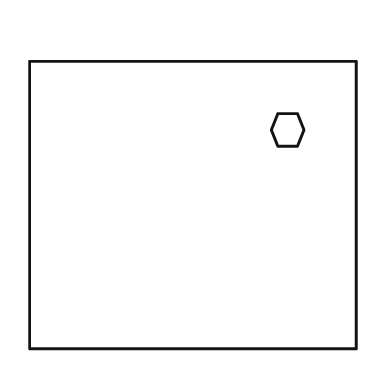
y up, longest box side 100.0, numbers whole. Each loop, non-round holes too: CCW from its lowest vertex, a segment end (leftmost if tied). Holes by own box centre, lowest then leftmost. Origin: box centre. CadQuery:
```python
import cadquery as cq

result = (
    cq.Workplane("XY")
    .moveTo(-50.0, -44.0)
    .lineTo(50.0, -44.0)
    .lineTo(50.0, 44.0)
    .lineTo(-50.0, 44.0)
    .close()
    .moveTo(26.0, 18.0)
    .lineTo(32.0, 18.0)
    .lineTo(34.0, 23.0)
    .lineTo(32.0, 28.0)
    .lineTo(26.0, 28.0)
    .lineTo(24.0, 23.0)
    .close()
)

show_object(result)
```